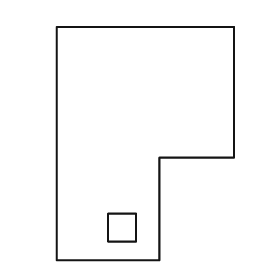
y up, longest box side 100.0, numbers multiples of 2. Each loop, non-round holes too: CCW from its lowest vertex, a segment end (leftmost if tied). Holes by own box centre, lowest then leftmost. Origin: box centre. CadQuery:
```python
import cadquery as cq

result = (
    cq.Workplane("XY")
    .moveTo(-38.0, -50.0)
    .lineTo(6.0, -50.0)
    .lineTo(6.0, -6.0)
    .lineTo(38.0, -6.0)
    .lineTo(38.0, 50.0)
    .lineTo(-38.0, 50.0)
    .close()
    .moveTo(-16.0, -42.0)
    .lineTo(-4.0, -42.0)
    .lineTo(-4.0, -30.0)
    .lineTo(-16.0, -30.0)
    .close()
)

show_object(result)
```